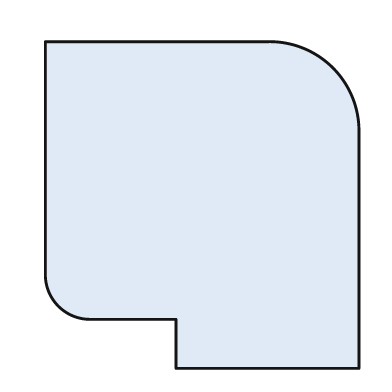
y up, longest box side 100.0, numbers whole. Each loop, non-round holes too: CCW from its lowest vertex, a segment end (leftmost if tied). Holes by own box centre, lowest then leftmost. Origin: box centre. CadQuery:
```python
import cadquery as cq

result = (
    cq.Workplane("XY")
    .moveTo(-8.0, -50.0)
    .lineTo(48.0, -50.0)
    .lineTo(48.0, 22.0)
    .threePointArc((40.0, 42.0), (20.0, 50.0))
    .lineTo(-48.0, 50.0)
    .lineTo(-48.0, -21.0)
    .threePointArc((-44.0, -31.0), (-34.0, -35.0))
    .lineTo(-8.0, -35.0)
    .close()
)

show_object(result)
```